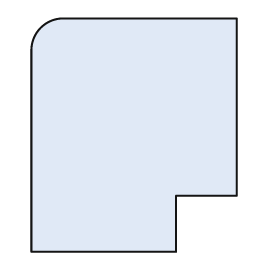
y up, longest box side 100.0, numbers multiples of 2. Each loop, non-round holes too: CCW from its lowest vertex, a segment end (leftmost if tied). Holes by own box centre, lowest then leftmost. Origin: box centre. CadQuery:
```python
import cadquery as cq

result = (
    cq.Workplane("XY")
    .moveTo(-44.0, -50.0)
    .lineTo(18.0, -50.0)
    .lineTo(18.0, -26.0)
    .lineTo(44.0, -26.0)
    .lineTo(44.0, 50.0)
    .lineTo(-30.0, 50.0)
    .threePointArc((-40.0, 46.0), (-44.0, 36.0))
    .close()
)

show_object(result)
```